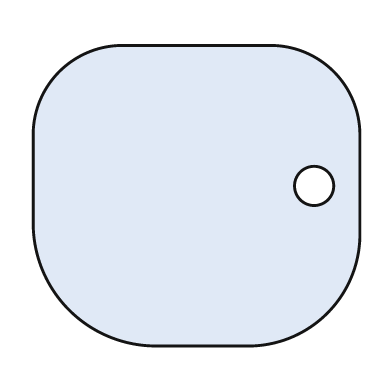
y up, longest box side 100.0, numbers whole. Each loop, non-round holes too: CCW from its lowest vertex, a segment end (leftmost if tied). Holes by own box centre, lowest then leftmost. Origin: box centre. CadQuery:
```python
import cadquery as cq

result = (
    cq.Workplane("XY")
    .moveTo(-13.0, -46.0)
    .lineTo(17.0, -46.0)
    .threePointArc((40.0, -36.0), (50.0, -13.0))
    .lineTo(50.0, 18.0)
    .threePointArc((42.0, 38.0), (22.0, 46.0))
    .lineTo(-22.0, 46.0)
    .threePointArc((-42.0, 38.0), (-50.0, 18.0))
    .lineTo(-50.0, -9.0)
    .threePointArc((-39.0, -35.0), (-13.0, -46.0))
    .close()
    .moveTo(36.0, 3.0)
    .circle(6.0)
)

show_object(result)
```